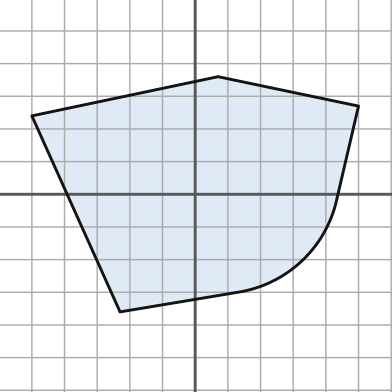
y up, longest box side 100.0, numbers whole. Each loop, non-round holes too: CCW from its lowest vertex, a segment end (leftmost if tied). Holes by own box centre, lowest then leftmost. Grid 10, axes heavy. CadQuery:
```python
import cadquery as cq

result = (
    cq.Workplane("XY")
    .moveTo(-23.0, -36.0)
    .lineTo(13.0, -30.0)
    .threePointArc((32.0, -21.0), (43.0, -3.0))
    .lineTo(50.0, 27.0)
    .lineTo(7.0, 36.0)
    .lineTo(-50.0, 24.0)
    .close()
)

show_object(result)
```